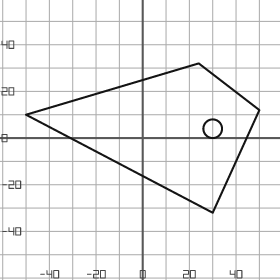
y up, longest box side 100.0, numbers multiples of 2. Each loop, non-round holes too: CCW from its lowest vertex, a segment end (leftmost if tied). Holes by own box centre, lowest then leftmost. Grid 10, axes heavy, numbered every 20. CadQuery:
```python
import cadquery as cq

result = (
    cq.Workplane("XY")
    .moveTo(30.0, -32.0)
    .lineTo(50.0, 12.0)
    .lineTo(24.0, 32.0)
    .lineTo(-50.0, 10.0)
    .close()
    .moveTo(30.0, 4.0)
    .circle(4.0)
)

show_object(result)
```